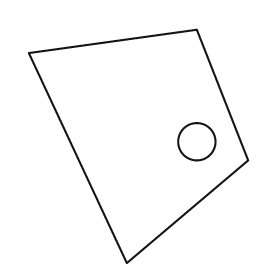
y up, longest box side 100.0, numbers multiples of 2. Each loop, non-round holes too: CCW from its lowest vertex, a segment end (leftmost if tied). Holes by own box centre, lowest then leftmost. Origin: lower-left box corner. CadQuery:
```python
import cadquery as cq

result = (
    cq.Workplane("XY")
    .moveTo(42.0, 0.0)
    .lineTo(94.0, 44.0)
    .lineTo(72.0, 100.0)
    .lineTo(0.0, 90.0)
    .close()
    .moveTo(72.0, 52.0)
    .circle(8.0)
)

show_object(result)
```